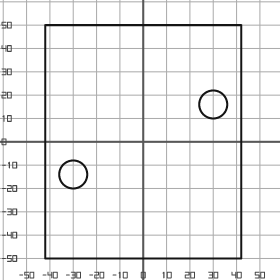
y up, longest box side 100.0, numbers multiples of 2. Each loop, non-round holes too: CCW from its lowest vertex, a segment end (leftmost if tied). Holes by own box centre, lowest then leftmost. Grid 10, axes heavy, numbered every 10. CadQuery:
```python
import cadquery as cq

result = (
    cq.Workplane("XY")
    .moveTo(-42.0, -50.0)
    .lineTo(42.0, -50.0)
    .lineTo(42.0, 50.0)
    .lineTo(-42.0, 50.0)
    .close()
    .moveTo(-30.0, -14.0)
    .circle(6.0)
    .moveTo(30.0, 16.0)
    .circle(6.0)
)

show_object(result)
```